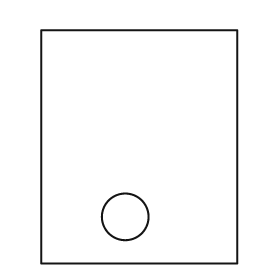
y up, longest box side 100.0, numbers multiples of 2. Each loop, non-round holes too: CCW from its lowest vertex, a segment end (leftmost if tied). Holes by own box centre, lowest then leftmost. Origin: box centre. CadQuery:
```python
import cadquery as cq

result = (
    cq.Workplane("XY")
    .moveTo(-42.0, -50.0)
    .lineTo(42.0, -50.0)
    .lineTo(42.0, 50.0)
    .lineTo(-42.0, 50.0)
    .close()
    .moveTo(-6.0, -30.0)
    .circle(10.0)
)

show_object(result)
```